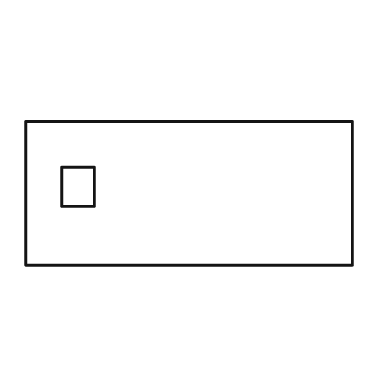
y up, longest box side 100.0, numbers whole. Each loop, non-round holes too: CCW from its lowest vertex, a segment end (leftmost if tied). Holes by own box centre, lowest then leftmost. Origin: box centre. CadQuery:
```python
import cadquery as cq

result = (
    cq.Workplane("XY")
    .moveTo(-50.0, -22.0)
    .lineTo(50.0, -22.0)
    .lineTo(50.0, 22.0)
    .lineTo(-50.0, 22.0)
    .close()
    .moveTo(-39.0, -4.0)
    .lineTo(-29.0, -4.0)
    .lineTo(-29.0, 8.0)
    .lineTo(-39.0, 8.0)
    .close()
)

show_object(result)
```